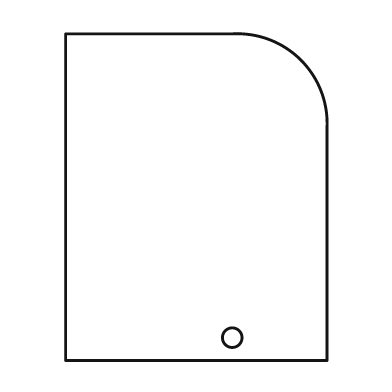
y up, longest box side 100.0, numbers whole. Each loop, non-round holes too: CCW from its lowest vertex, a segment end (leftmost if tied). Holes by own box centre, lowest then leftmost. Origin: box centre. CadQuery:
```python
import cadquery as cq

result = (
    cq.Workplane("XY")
    .moveTo(-40.0, -50.0)
    .lineTo(40.0, -50.0)
    .lineTo(40.0, 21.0)
    .threePointArc((32.0, 42.0), (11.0, 50.0))
    .lineTo(-40.0, 50.0)
    .close()
    .moveTo(11.0, -43.0)
    .circle(3.0)
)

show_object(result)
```